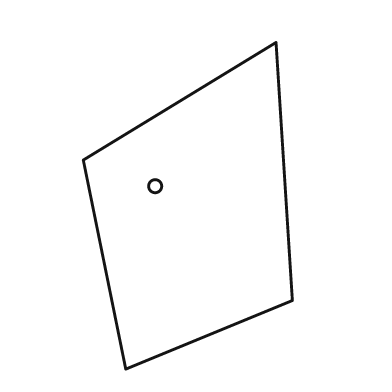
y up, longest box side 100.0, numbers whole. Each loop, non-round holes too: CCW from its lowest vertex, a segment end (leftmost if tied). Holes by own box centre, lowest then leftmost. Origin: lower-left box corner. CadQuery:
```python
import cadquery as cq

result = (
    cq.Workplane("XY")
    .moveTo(13.0, 0.0)
    .lineTo(64.0, 21.0)
    .lineTo(59.0, 100.0)
    .lineTo(0.0, 64.0)
    .close()
    .moveTo(22.0, 56.0)
    .circle(2.0)
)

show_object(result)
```